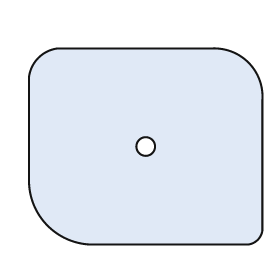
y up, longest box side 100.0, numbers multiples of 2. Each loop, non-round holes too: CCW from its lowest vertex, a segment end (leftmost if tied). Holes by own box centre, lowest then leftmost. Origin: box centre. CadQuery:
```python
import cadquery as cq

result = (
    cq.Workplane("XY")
    .moveTo(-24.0, -42.0)
    .lineTo(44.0, -42.0)
    .threePointArc((48.0, -40.0), (50.0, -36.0))
    .lineTo(50.0, 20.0)
    .threePointArc((44.0, 36.0), (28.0, 42.0))
    .lineTo(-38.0, 42.0)
    .threePointArc((-46.0, 38.0), (-50.0, 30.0))
    .lineTo(-50.0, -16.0)
    .threePointArc((-42.0, -34.0), (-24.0, -42.0))
    .close()
    .moveTo(0.0, 0.0)
    .circle(4.0)
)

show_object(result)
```